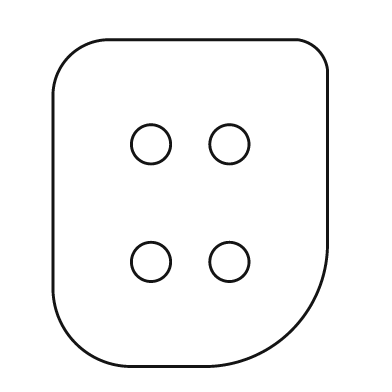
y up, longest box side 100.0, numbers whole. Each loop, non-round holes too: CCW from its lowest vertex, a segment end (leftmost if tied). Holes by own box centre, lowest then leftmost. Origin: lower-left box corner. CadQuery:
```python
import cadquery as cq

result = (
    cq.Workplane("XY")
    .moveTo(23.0, 0.0)
    .lineTo(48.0, 0.0)
    .threePointArc((73.0, 11.0), (84.0, 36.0))
    .lineTo(84.0, 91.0)
    .threePointArc((81.0, 97.0), (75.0, 100.0))
    .lineTo(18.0, 100.0)
    .threePointArc((5.0, 95.0), (0.0, 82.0))
    .lineTo(0.0, 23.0)
    .threePointArc((7.0, 7.0), (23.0, 0.0))
    .close()
    .moveTo(30.0, 32.0)
    .circle(6.0)
    .moveTo(54.0, 32.0)
    .circle(6.0)
    .moveTo(30.0, 68.0)
    .circle(6.0)
    .moveTo(54.0, 68.0)
    .circle(6.0)
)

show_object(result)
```